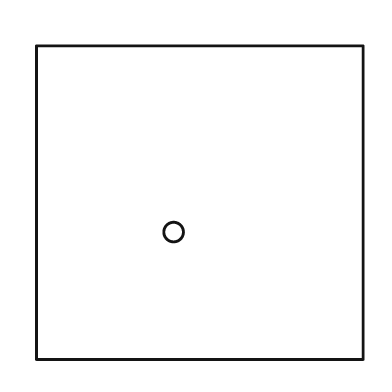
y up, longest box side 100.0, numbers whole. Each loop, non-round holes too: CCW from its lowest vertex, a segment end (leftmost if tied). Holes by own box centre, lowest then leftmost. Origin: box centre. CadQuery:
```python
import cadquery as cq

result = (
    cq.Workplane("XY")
    .moveTo(-50.0, -48.0)
    .lineTo(50.0, -48.0)
    .lineTo(50.0, 48.0)
    .lineTo(-50.0, 48.0)
    .close()
    .moveTo(-8.0, -9.0)
    .circle(3.0)
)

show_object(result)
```